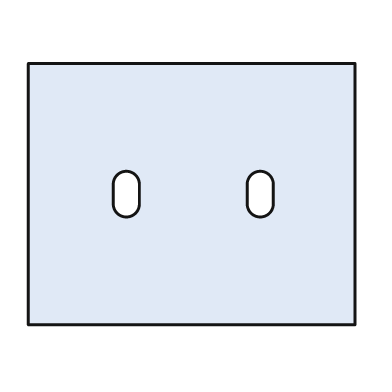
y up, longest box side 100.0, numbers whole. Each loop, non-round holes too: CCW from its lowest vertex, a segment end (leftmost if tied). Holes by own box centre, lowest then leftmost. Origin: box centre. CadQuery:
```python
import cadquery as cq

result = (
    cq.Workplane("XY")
    .moveTo(-50.0, -40.0)
    .lineTo(50.0, -40.0)
    .lineTo(50.0, 40.0)
    .lineTo(-50.0, 40.0)
    .close()
    .moveTo(-24.0, -3.0)
    .threePointArc((-20.0, -7.0), (-16.0, -3.0))
    .lineTo(-16.0, 3.0)
    .threePointArc((-20.0, 7.0), (-24.0, 3.0))
    .close()
    .moveTo(17.0, -3.0)
    .threePointArc((21.0, -7.0), (25.0, -3.0))
    .lineTo(25.0, 3.0)
    .threePointArc((21.0, 7.0), (17.0, 3.0))
    .close()
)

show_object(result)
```